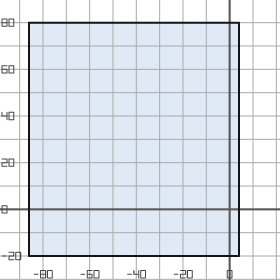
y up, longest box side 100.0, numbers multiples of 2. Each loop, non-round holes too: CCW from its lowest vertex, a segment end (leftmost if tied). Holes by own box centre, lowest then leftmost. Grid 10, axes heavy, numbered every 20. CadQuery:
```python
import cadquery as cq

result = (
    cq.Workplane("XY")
    .moveTo(-86.0, -20.0)
    .lineTo(4.0, -20.0)
    .lineTo(4.0, 80.0)
    .lineTo(-86.0, 80.0)
    .close()
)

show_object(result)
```